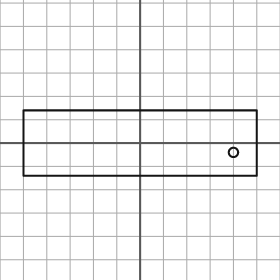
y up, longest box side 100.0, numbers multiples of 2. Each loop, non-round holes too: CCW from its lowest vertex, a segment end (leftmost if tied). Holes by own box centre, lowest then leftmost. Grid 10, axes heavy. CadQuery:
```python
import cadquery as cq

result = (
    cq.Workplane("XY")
    .moveTo(-50.0, -14.0)
    .lineTo(50.0, -14.0)
    .lineTo(50.0, 14.0)
    .lineTo(-50.0, 14.0)
    .close()
    .moveTo(40.0, -4.0)
    .circle(2.0)
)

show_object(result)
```